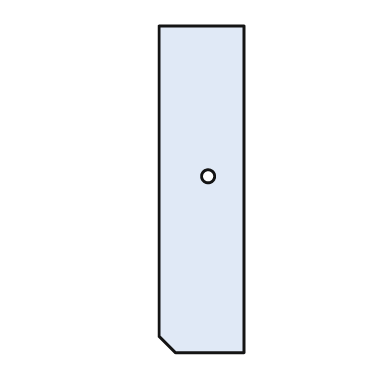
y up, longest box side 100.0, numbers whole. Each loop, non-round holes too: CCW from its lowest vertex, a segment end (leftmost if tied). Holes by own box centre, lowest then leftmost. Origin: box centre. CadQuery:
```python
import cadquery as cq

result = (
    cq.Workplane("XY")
    .moveTo(-8.0, -50.0)
    .lineTo(13.0, -50.0)
    .lineTo(13.0, 50.0)
    .lineTo(-13.0, 50.0)
    .lineTo(-13.0, -45.0)
    .close()
    .moveTo(2.0, 4.0)
    .circle(2.0)
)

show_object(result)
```